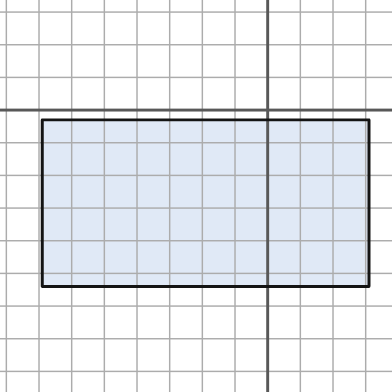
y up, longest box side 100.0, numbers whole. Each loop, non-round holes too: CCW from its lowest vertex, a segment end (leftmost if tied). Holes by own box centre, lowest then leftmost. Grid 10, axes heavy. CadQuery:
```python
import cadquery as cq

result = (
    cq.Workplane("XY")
    .moveTo(-69.0, -54.0)
    .lineTo(31.0, -54.0)
    .lineTo(31.0, -3.0)
    .lineTo(-69.0, -3.0)
    .close()
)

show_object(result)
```